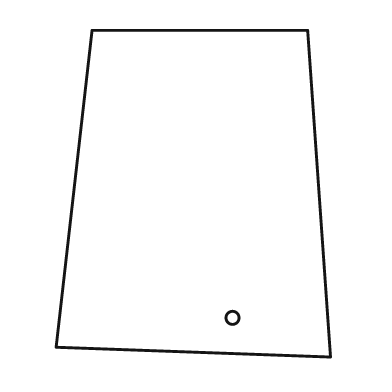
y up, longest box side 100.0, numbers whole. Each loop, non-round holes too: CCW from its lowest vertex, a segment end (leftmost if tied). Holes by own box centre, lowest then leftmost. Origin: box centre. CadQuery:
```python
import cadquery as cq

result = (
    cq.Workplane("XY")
    .moveTo(42.0, -50.0)
    .lineTo(35.0, 50.0)
    .lineTo(-31.0, 50.0)
    .lineTo(-42.0, -47.0)
    .close()
    .moveTo(12.0, -38.0)
    .circle(2.0)
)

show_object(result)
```